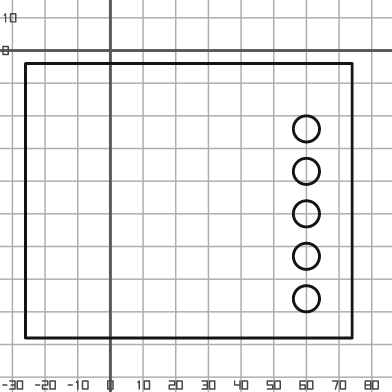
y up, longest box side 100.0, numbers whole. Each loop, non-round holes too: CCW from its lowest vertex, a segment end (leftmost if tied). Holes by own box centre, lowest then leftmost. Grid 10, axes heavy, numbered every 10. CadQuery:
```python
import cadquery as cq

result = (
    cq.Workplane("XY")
    .moveTo(-26.0, -88.0)
    .lineTo(74.0, -88.0)
    .lineTo(74.0, -4.0)
    .lineTo(-26.0, -4.0)
    .close()
    .moveTo(60.0, -76.0)
    .circle(4.0)
    .moveTo(60.0, -63.0)
    .circle(4.0)
    .moveTo(60.0, -50.0)
    .circle(4.0)
    .moveTo(60.0, -37.0)
    .circle(4.0)
    .moveTo(60.0, -24.0)
    .circle(4.0)
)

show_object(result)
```